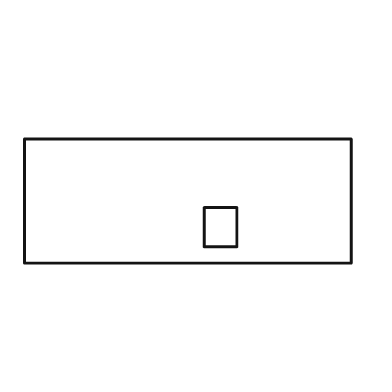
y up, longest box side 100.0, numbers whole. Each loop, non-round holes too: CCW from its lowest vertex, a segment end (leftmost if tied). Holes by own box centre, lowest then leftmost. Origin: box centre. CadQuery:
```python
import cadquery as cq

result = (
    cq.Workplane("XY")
    .moveTo(-50.0, -19.0)
    .lineTo(50.0, -19.0)
    .lineTo(50.0, 19.0)
    .lineTo(-50.0, 19.0)
    .close()
    .moveTo(5.0, -14.0)
    .lineTo(15.0, -14.0)
    .lineTo(15.0, -2.0)
    .lineTo(5.0, -2.0)
    .close()
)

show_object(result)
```